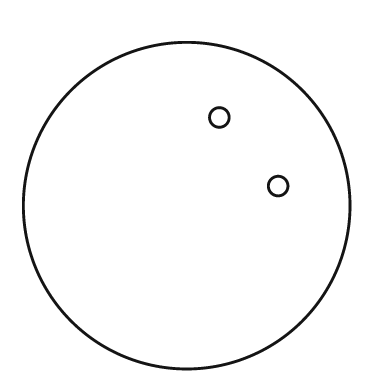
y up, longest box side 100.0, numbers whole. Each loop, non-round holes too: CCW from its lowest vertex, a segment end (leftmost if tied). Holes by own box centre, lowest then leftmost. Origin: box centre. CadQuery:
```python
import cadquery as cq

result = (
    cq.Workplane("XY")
    .moveTo(0.0, 0.0)
    .circle(50.0)
    .moveTo(28.0, 6.0)
    .circle(3.0)
    .moveTo(10.0, 27.0)
    .circle(3.0)
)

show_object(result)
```